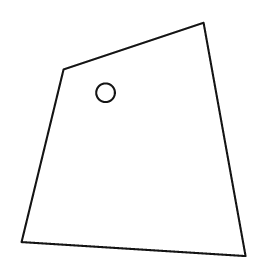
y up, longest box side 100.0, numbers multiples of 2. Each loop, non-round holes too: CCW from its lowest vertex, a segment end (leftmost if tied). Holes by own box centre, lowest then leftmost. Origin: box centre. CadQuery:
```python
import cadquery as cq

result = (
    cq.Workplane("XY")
    .moveTo(48.0, -50.0)
    .lineTo(30.0, 50.0)
    .lineTo(-30.0, 30.0)
    .lineTo(-48.0, -44.0)
    .close()
    .moveTo(-12.0, 20.0)
    .circle(4.0)
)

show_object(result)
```